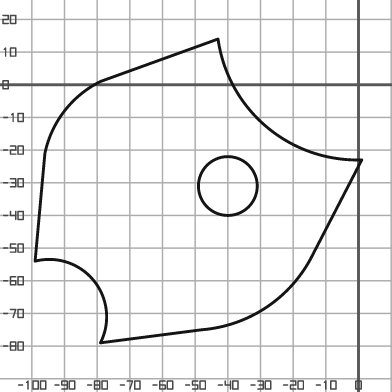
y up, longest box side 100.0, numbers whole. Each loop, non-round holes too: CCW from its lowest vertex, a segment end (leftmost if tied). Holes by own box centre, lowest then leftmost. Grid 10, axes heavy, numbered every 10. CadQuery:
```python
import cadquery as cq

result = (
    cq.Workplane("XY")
    .moveTo(-79.0, -79.0)
    .lineTo(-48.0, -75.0)
    .threePointArc((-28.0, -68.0), (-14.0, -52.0))
    .lineTo(1.0, -23.0)
    .threePointArc((-28.0, -13.0), (-43.0, 14.0))
    .lineTo(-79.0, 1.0)
    .threePointArc((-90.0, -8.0), (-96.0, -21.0))
    .lineTo(-99.0, -54.0)
    .threePointArc((-81.0, -60.0), (-79.0, -79.0))
    .close()
    .moveTo(-40.0, -31.0)
    .circle(9.0)
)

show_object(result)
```